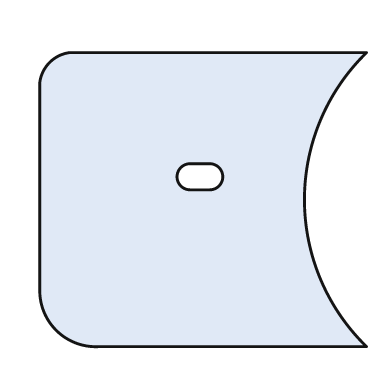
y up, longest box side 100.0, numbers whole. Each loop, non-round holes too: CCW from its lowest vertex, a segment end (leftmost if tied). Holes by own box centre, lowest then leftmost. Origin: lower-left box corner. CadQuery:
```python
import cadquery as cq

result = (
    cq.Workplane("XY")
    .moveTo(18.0, 0.0)
    .lineTo(100.0, 0.0)
    .threePointArc((81.0, 45.0), (100.0, 90.0))
    .lineTo(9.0, 90.0)
    .threePointArc((3.0, 87.0), (0.0, 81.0))
    .lineTo(0.0, 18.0)
    .threePointArc((5.0, 5.0), (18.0, 0.0))
    .close()
    .moveTo(46.0, 48.0)
    .lineTo(52.0, 48.0)
    .threePointArc((56.0, 52.0), (52.0, 56.0))
    .lineTo(46.0, 56.0)
    .threePointArc((42.0, 52.0), (46.0, 48.0))
    .close()
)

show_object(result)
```